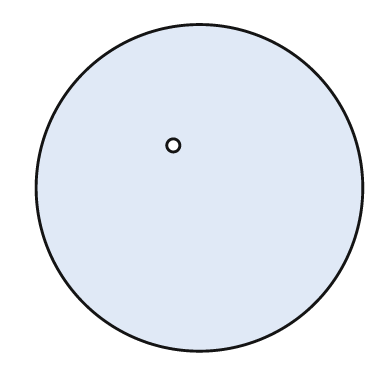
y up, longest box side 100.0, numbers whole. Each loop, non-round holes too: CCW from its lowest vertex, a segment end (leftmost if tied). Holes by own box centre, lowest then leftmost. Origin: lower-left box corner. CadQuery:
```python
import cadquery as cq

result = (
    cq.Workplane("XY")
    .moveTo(50.0, 50.0)
    .circle(50.0)
    .moveTo(42.0, 63.0)
    .circle(2.0)
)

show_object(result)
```